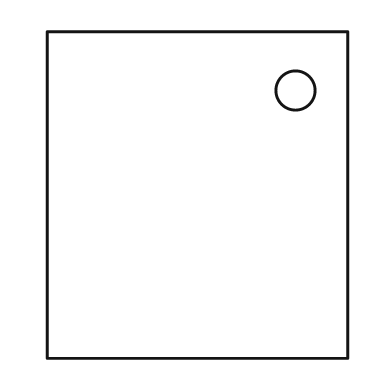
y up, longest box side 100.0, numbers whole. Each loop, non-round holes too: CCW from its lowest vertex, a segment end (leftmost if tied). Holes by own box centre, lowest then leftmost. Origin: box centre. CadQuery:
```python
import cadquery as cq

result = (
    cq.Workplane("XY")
    .moveTo(-46.0, -50.0)
    .lineTo(46.0, -50.0)
    .lineTo(46.0, 50.0)
    .lineTo(-46.0, 50.0)
    .close()
    .moveTo(30.0, 32.0)
    .circle(6.0)
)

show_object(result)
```